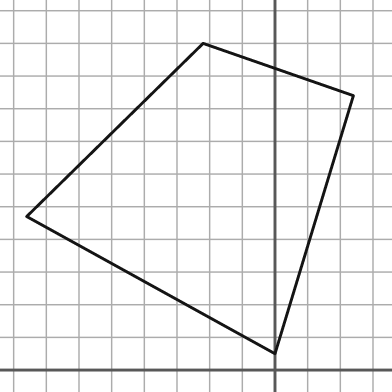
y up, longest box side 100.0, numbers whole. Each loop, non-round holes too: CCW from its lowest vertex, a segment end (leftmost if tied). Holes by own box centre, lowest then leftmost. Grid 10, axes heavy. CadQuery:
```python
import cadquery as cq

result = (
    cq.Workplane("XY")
    .moveTo(0.0, 5.0)
    .lineTo(24.0, 84.0)
    .lineTo(-22.0, 100.0)
    .lineTo(-76.0, 47.0)
    .close()
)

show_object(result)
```